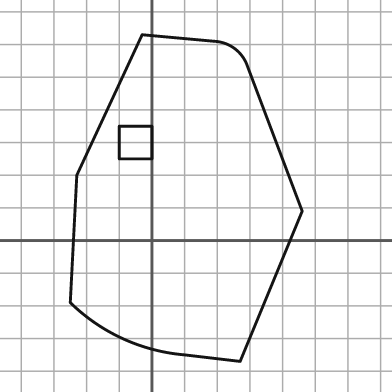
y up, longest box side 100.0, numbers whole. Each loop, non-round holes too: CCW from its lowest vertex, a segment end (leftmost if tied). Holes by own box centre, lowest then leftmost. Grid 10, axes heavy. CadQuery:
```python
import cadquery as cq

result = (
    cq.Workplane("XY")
    .moveTo(27.0, -37.0)
    .lineTo(46.0, 9.0)
    .lineTo(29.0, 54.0)
    .threePointArc((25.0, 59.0), (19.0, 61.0))
    .lineTo(-3.0, 63.0)
    .lineTo(-23.0, 20.0)
    .lineTo(-25.0, -19.0)
    .threePointArc((-9.0, -30.0), (10.0, -35.0))
    .close()
    .moveTo(-10.0, 25.0)
    .lineTo(0.0, 25.0)
    .lineTo(0.0, 35.0)
    .lineTo(-10.0, 35.0)
    .close()
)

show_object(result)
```